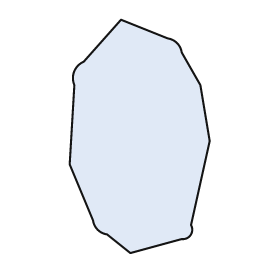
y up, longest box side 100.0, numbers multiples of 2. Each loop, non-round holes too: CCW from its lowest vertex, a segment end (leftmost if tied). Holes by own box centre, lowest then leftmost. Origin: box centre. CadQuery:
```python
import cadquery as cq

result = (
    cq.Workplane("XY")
    .moveTo(-4.0, -50.0)
    .lineTo(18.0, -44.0)
    .threePointArc((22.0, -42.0), (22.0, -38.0))
    .lineTo(30.0, -2.0)
    .lineTo(26.0, 22.0)
    .lineTo(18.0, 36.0)
    .threePointArc((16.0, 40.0), (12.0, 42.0))
    .lineTo(-8.0, 50.0)
    .lineTo(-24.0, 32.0)
    .threePointArc((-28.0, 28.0), (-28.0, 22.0))
    .lineTo(-30.0, -12.0)
    .lineTo(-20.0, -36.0)
    .threePointArc((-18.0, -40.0), (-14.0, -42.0))
    .close()
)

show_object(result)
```